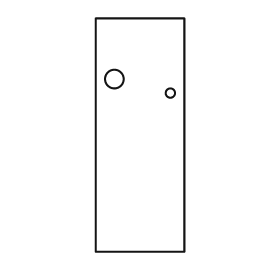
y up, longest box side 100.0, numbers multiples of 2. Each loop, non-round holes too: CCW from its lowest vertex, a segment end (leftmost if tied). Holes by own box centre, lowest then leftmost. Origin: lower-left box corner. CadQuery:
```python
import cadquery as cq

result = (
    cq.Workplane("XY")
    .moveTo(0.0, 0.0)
    .lineTo(38.0, 0.0)
    .lineTo(38.0, 100.0)
    .lineTo(0.0, 100.0)
    .close()
    .moveTo(32.0, 68.0)
    .circle(2.0)
    .moveTo(8.0, 74.0)
    .circle(4.0)
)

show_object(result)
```